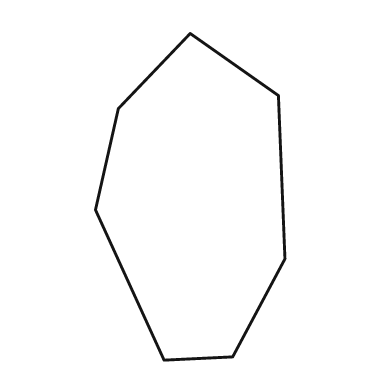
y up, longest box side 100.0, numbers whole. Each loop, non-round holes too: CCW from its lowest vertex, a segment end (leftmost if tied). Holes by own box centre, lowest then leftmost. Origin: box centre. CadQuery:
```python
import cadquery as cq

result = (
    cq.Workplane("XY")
    .moveTo(-8.0, -50.0)
    .lineTo(13.0, -49.0)
    .lineTo(29.0, -19.0)
    .lineTo(27.0, 31.0)
    .lineTo(0.0, 50.0)
    .lineTo(-22.0, 27.0)
    .lineTo(-29.0, -4.0)
    .close()
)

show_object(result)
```